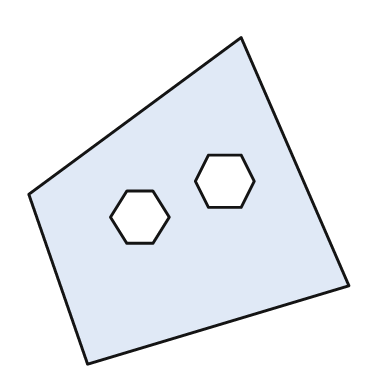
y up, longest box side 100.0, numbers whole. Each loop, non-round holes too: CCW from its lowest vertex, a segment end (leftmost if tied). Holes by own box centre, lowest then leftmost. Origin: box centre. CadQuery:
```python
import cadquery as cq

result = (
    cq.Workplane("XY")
    .moveTo(-31.0, -50.0)
    .lineTo(49.0, -26.0)
    .lineTo(16.0, 50.0)
    .lineTo(-49.0, 2.0)
    .close()
    .moveTo(-19.0, -13.0)
    .lineTo(-11.0, -13.0)
    .lineTo(-6.0, -5.0)
    .lineTo(-11.0, 3.0)
    .lineTo(-19.0, 3.0)
    .lineTo(-24.0, -5.0)
    .close()
    .moveTo(6.0, -2.0)
    .lineTo(16.0, -2.0)
    .lineTo(20.0, 6.0)
    .lineTo(16.0, 14.0)
    .lineTo(6.0, 14.0)
    .lineTo(2.0, 6.0)
    .close()
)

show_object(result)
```